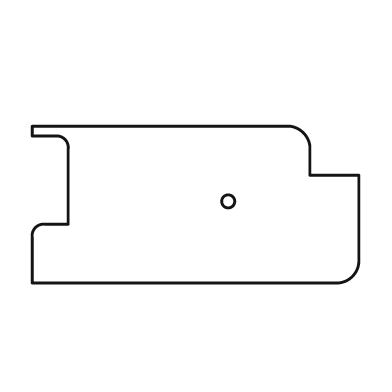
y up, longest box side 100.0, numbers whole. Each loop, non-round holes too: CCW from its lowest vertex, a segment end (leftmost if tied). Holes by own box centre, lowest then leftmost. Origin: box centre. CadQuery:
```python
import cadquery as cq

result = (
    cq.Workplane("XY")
    .moveTo(-50.0, -24.0)
    .lineTo(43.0, -24.0)
    .threePointArc((48.0, -22.0), (50.0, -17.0))
    .lineTo(50.0, 9.0)
    .lineTo(35.0, 9.0)
    .lineTo(35.0, 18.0)
    .threePointArc((33.0, 22.0), (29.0, 24.0))
    .lineTo(-50.0, 24.0)
    .lineTo(-50.0, 21.0)
    .lineTo(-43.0, 21.0)
    .threePointArc((-40.0, 20.0), (-39.0, 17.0))
    .lineTo(-39.0, -6.0)
    .lineTo(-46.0, -6.0)
    .threePointArc((-49.0, -7.0), (-50.0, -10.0))
    .close()
    .moveTo(10.0, 1.0)
    .circle(2.0)
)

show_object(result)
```